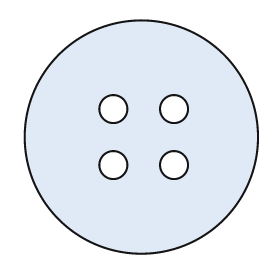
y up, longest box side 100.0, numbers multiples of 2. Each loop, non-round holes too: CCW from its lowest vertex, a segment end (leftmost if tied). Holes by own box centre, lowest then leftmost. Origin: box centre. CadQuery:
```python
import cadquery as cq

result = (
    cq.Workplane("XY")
    .moveTo(0.0, 0.0)
    .circle(50.0)
    .moveTo(-12.0, -12.0)
    .circle(6.0)
    .moveTo(14.0, -12.0)
    .circle(6.0)
    .moveTo(-12.0, 12.0)
    .circle(6.0)
    .moveTo(14.0, 12.0)
    .circle(6.0)
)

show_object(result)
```